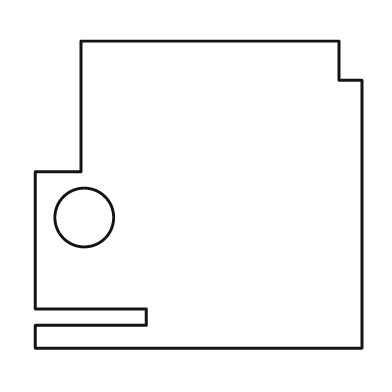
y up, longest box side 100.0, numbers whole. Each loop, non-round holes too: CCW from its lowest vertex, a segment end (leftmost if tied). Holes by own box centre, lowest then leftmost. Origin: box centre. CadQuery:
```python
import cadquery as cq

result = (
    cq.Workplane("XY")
    .moveTo(-50.0, -47.0)
    .lineTo(50.0, -47.0)
    .lineTo(50.0, 35.0)
    .lineTo(43.0, 35.0)
    .lineTo(43.0, 47.0)
    .lineTo(-36.0, 47.0)
    .lineTo(-36.0, 7.0)
    .lineTo(-50.0, 7.0)
    .lineTo(-50.0, -35.0)
    .lineTo(-16.0, -35.0)
    .lineTo(-16.0, -40.0)
    .lineTo(-50.0, -40.0)
    .close()
    .moveTo(-35.0, -7.0)
    .circle(9.0)
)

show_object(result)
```